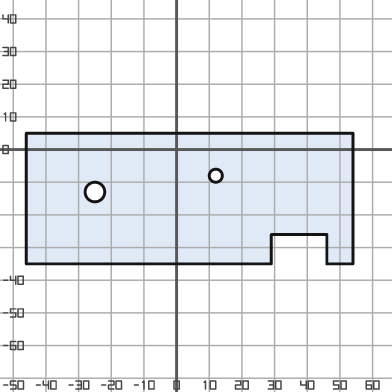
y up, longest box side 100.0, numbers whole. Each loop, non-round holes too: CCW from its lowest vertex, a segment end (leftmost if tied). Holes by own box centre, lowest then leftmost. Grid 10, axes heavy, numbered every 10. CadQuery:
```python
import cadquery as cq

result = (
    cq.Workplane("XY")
    .moveTo(-46.0, -35.0)
    .lineTo(29.0, -35.0)
    .lineTo(29.0, -26.0)
    .lineTo(46.0, -26.0)
    .lineTo(46.0, -35.0)
    .lineTo(54.0, -35.0)
    .lineTo(54.0, 5.0)
    .lineTo(-46.0, 5.0)
    .close()
    .moveTo(-25.0, -13.0)
    .circle(3.0)
    .moveTo(12.0, -8.0)
    .circle(2.0)
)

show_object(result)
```